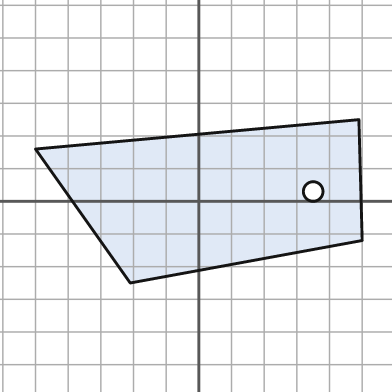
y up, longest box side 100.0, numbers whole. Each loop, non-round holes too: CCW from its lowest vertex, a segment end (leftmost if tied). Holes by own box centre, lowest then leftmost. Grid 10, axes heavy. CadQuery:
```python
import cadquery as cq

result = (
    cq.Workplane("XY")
    .moveTo(-21.0, -25.0)
    .lineTo(50.0, -12.0)
    .lineTo(49.0, 25.0)
    .lineTo(-50.0, 16.0)
    .close()
    .moveTo(35.0, 3.0)
    .circle(3.0)
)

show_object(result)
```